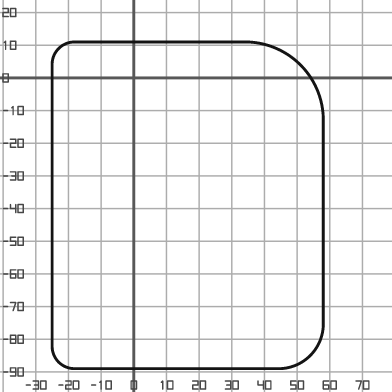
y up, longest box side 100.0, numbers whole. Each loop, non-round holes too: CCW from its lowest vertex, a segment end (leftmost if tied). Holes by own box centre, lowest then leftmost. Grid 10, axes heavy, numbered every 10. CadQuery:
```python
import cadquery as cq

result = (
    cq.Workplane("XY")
    .moveTo(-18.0, -89.0)
    .lineTo(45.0, -89.0)
    .threePointArc((54.0, -85.0), (58.0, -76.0))
    .lineTo(58.0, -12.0)
    .threePointArc((51.0, 4.0), (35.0, 11.0))
    .lineTo(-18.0, 11.0)
    .threePointArc((-23.0, 9.0), (-25.0, 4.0))
    .lineTo(-25.0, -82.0)
    .threePointArc((-23.0, -87.0), (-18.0, -89.0))
    .close()
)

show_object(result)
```